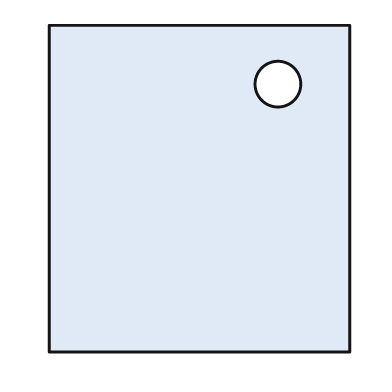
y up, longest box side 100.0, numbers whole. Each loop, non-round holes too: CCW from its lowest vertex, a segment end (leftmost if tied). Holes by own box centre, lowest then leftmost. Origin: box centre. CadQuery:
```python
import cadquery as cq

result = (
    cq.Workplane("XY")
    .moveTo(-46.0, -50.0)
    .lineTo(46.0, -50.0)
    .lineTo(46.0, 50.0)
    .lineTo(-46.0, 50.0)
    .close()
    .moveTo(24.0, 32.0)
    .circle(7.0)
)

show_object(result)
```